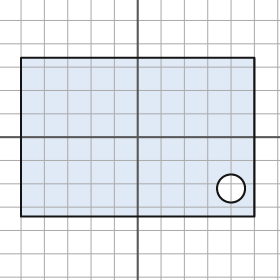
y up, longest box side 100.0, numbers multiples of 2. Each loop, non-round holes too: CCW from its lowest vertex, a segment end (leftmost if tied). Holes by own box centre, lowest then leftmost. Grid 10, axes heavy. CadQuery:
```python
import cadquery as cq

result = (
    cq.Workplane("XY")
    .moveTo(-50.0, -34.0)
    .lineTo(50.0, -34.0)
    .lineTo(50.0, 34.0)
    .lineTo(-50.0, 34.0)
    .close()
    .moveTo(40.0, -22.0)
    .circle(6.0)
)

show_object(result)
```